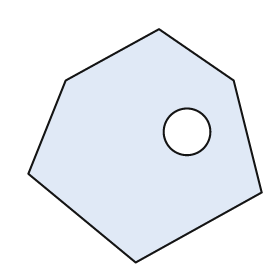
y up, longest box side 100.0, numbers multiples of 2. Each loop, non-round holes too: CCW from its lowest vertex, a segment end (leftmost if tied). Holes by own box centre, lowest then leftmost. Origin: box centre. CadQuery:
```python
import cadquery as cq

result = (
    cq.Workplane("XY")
    .moveTo(-4.0, -50.0)
    .lineTo(50.0, -20.0)
    .lineTo(38.0, 28.0)
    .lineTo(6.0, 50.0)
    .lineTo(-34.0, 28.0)
    .lineTo(-50.0, -12.0)
    .close()
    .moveTo(18.0, 6.0)
    .circle(10.0)
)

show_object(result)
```